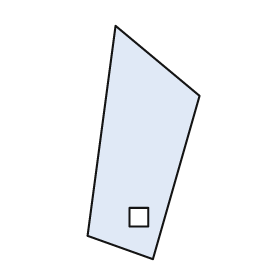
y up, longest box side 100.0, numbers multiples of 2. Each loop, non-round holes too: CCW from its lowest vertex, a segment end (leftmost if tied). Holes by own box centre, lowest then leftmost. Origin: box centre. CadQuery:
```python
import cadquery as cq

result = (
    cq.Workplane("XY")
    .moveTo(4.0, -50.0)
    .lineTo(24.0, 20.0)
    .lineTo(-12.0, 50.0)
    .lineTo(-24.0, -40.0)
    .close()
    .moveTo(-6.0, -36.0)
    .lineTo(2.0, -36.0)
    .lineTo(2.0, -28.0)
    .lineTo(-6.0, -28.0)
    .close()
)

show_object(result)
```